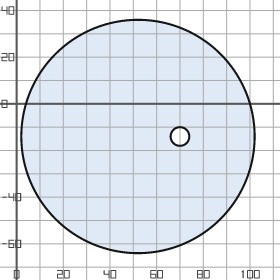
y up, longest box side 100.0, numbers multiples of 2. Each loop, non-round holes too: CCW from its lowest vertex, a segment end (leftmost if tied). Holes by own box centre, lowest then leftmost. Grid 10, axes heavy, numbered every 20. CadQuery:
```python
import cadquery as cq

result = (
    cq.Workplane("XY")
    .moveTo(52.0, -14.0)
    .circle(50.0)
    .moveTo(70.0, -14.0)
    .circle(4.0)
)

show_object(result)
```